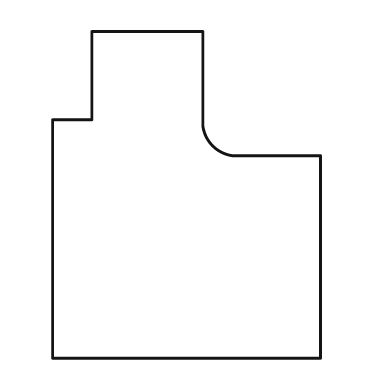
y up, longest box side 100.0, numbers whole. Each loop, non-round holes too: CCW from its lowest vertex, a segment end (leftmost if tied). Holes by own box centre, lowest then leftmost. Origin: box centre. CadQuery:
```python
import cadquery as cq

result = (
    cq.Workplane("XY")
    .moveTo(-41.0, -50.0)
    .lineTo(41.0, -50.0)
    .lineTo(41.0, 12.0)
    .lineTo(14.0, 12.0)
    .threePointArc((8.0, 15.0), (5.0, 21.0))
    .lineTo(5.0, 50.0)
    .lineTo(-29.0, 50.0)
    .lineTo(-29.0, 23.0)
    .lineTo(-41.0, 23.0)
    .close()
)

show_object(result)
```